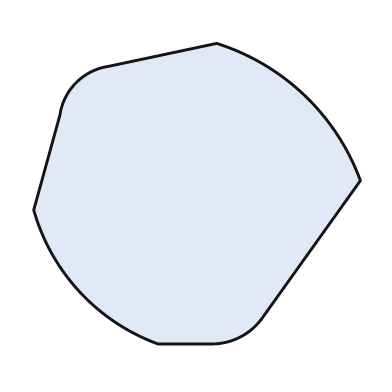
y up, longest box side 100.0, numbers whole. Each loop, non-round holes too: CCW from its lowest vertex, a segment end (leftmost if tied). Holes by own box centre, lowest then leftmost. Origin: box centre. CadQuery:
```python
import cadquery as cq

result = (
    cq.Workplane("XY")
    .moveTo(-12.0, -46.0)
    .lineTo(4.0, -46.0)
    .threePointArc((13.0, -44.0), (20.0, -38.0))
    .lineTo(50.0, 4.0)
    .threePointArc((33.0, 30.0), (6.0, 46.0))
    .lineTo(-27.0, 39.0)
    .threePointArc((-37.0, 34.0), (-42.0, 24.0))
    .lineTo(-50.0, -5.0)
    .threePointArc((-36.0, -30.0), (-12.0, -46.0))
    .close()
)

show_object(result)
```